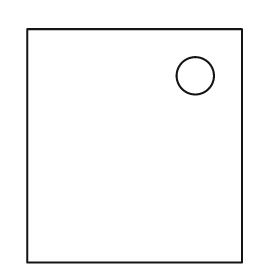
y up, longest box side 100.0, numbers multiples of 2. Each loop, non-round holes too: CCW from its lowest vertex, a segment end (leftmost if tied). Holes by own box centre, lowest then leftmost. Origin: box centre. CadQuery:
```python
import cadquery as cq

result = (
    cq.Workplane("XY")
    .moveTo(-46.0, -50.0)
    .lineTo(46.0, -50.0)
    .lineTo(46.0, 50.0)
    .lineTo(-46.0, 50.0)
    .close()
    .moveTo(26.0, 30.0)
    .circle(8.0)
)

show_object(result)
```